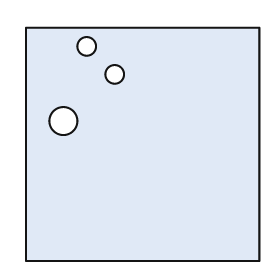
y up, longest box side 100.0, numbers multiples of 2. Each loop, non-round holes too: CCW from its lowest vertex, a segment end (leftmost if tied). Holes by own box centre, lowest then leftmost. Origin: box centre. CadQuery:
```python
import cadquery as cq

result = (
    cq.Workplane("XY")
    .moveTo(-50.0, -50.0)
    .lineTo(50.0, -50.0)
    .lineTo(50.0, 50.0)
    .lineTo(-50.0, 50.0)
    .close()
    .moveTo(-34.0, 10.0)
    .circle(6.0)
    .moveTo(-12.0, 30.0)
    .circle(4.0)
    .moveTo(-24.0, 42.0)
    .circle(4.0)
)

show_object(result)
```